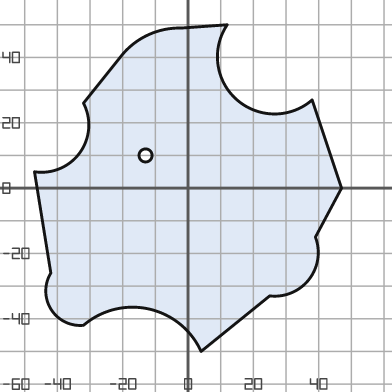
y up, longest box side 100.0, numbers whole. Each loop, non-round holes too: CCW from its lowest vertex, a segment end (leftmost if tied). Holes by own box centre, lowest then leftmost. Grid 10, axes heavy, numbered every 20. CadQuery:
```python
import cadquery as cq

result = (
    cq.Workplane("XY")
    .moveTo(4.0, -50.0)
    .lineTo(25.0, -33.0)
    .threePointArc((37.0, -28.0), (39.0, -15.0))
    .lineTo(47.0, 0.0)
    .lineTo(38.0, 27.0)
    .threePointArc((15.0, 27.0), (12.0, 50.0))
    .lineTo(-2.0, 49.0)
    .threePointArc((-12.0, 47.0), (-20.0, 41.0))
    .lineTo(-32.0, 26.0)
    .threePointArc((-33.0, 11.0), (-47.0, 5.0))
    .lineTo(-42.0, -26.0)
    .threePointArc((-42.0, -37.0), (-32.0, -42.0))
    .threePointArc((-12.0, -37.0), (4.0, -50.0))
    .close()
    .moveTo(-13.0, 10.0)
    .circle(2.0)
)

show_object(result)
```